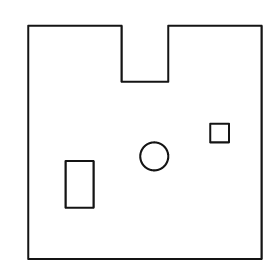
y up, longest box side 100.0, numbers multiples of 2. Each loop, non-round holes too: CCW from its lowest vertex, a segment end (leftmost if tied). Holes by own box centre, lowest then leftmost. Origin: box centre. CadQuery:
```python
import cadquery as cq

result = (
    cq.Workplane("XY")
    .moveTo(-50.0, -50.0)
    .lineTo(50.0, -50.0)
    .lineTo(50.0, 50.0)
    .lineTo(10.0, 50.0)
    .lineTo(10.0, 26.0)
    .lineTo(-10.0, 26.0)
    .lineTo(-10.0, 50.0)
    .lineTo(-50.0, 50.0)
    .close()
    .moveTo(-34.0, -28.0)
    .lineTo(-22.0, -28.0)
    .lineTo(-22.0, -8.0)
    .lineTo(-34.0, -8.0)
    .close()
    .moveTo(4.0, -6.0)
    .circle(6.0)
    .moveTo(28.0, 0.0)
    .lineTo(36.0, 0.0)
    .lineTo(36.0, 8.0)
    .lineTo(28.0, 8.0)
    .close()
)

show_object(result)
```